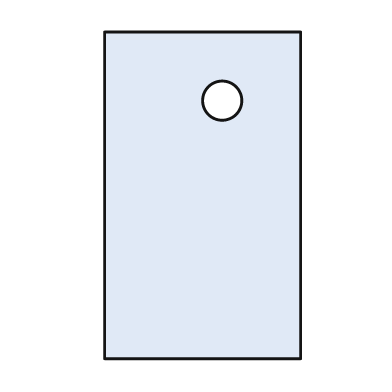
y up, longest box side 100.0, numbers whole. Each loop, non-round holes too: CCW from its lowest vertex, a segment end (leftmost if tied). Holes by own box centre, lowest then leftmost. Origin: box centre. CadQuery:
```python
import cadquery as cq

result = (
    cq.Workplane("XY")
    .moveTo(-30.0, -50.0)
    .lineTo(30.0, -50.0)
    .lineTo(30.0, 50.0)
    .lineTo(-30.0, 50.0)
    .close()
    .moveTo(6.0, 29.0)
    .circle(6.0)
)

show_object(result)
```